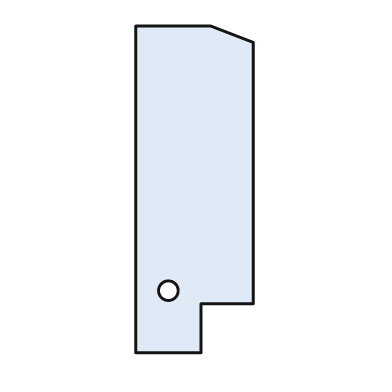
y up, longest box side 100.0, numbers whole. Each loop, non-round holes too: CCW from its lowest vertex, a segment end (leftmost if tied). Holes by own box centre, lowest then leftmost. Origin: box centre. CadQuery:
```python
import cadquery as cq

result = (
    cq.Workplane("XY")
    .moveTo(-18.0, -50.0)
    .lineTo(2.0, -50.0)
    .lineTo(2.0, -35.0)
    .lineTo(18.0, -35.0)
    .lineTo(18.0, 45.0)
    .lineTo(5.0, 50.0)
    .lineTo(-18.0, 50.0)
    .close()
    .moveTo(-8.0, -31.0)
    .circle(3.0)
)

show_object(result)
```